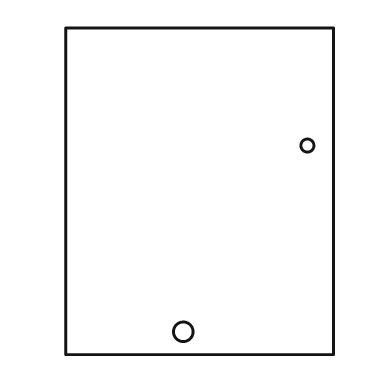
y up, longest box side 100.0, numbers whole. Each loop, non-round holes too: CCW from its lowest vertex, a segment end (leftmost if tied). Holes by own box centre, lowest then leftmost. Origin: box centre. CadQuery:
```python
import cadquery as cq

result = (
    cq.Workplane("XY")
    .moveTo(-41.0, -50.0)
    .lineTo(41.0, -50.0)
    .lineTo(41.0, 50.0)
    .lineTo(-41.0, 50.0)
    .close()
    .moveTo(-5.0, -43.0)
    .circle(3.0)
    .moveTo(33.0, 14.0)
    .circle(2.0)
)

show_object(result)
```